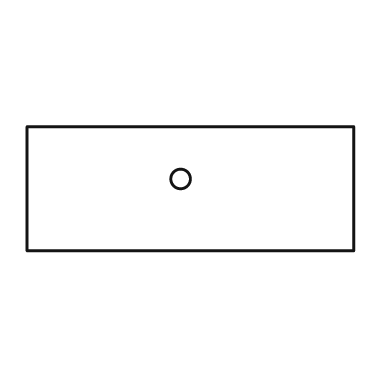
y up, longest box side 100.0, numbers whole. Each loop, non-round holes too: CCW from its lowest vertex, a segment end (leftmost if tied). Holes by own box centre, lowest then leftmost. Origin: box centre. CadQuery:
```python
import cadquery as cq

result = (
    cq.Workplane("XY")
    .moveTo(-50.0, -19.0)
    .lineTo(50.0, -19.0)
    .lineTo(50.0, 19.0)
    .lineTo(-50.0, 19.0)
    .close()
    .moveTo(-3.0, 3.0)
    .circle(3.0)
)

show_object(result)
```